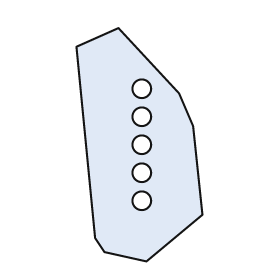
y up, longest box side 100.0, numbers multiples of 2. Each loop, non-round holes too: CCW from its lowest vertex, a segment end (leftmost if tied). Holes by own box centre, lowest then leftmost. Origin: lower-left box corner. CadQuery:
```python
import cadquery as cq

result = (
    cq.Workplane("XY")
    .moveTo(30.0, 0.0)
    .lineTo(54.0, 20.0)
    .lineTo(50.0, 58.0)
    .lineTo(44.0, 72.0)
    .lineTo(18.0, 100.0)
    .lineTo(0.0, 92.0)
    .lineTo(8.0, 10.0)
    .lineTo(12.0, 4.0)
    .close()
    .moveTo(28.0, 26.0)
    .circle(4.0)
    .moveTo(28.0, 38.0)
    .circle(4.0)
    .moveTo(28.0, 50.0)
    .circle(4.0)
    .moveTo(28.0, 62.0)
    .circle(4.0)
    .moveTo(28.0, 74.0)
    .circle(4.0)
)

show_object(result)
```